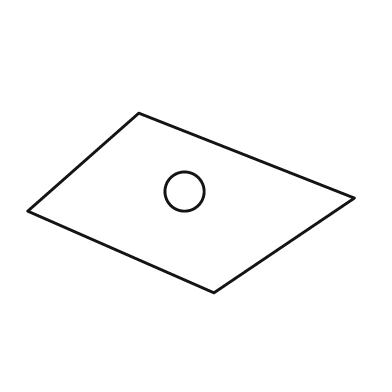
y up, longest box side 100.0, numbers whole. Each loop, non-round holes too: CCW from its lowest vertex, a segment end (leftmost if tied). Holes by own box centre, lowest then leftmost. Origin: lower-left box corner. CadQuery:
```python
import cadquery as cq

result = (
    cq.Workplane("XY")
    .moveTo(57.0, 0.0)
    .lineTo(100.0, 29.0)
    .lineTo(34.0, 55.0)
    .lineTo(0.0, 25.0)
    .close()
    .moveTo(48.0, 31.0)
    .circle(6.0)
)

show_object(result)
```